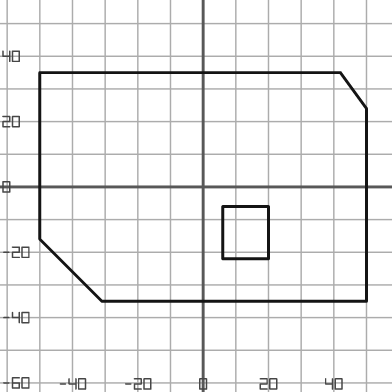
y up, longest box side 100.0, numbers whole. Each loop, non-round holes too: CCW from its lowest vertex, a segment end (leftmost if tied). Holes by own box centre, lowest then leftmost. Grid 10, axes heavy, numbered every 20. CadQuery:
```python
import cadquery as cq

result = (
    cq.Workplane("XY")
    .moveTo(-31.0, -35.0)
    .lineTo(50.0, -35.0)
    .lineTo(50.0, 24.0)
    .lineTo(42.0, 35.0)
    .lineTo(-50.0, 35.0)
    .lineTo(-50.0, -16.0)
    .close()
    .moveTo(6.0, -22.0)
    .lineTo(20.0, -22.0)
    .lineTo(20.0, -6.0)
    .lineTo(6.0, -6.0)
    .close()
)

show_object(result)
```